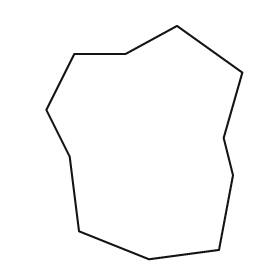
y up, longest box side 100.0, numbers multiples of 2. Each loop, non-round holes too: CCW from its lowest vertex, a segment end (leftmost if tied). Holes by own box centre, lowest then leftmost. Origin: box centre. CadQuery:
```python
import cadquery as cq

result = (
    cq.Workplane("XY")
    .moveTo(2.0, -50.0)
    .lineTo(32.0, -46.0)
    .lineTo(38.0, -14.0)
    .lineTo(34.0, 2.0)
    .lineTo(42.0, 30.0)
    .lineTo(14.0, 50.0)
    .lineTo(-8.0, 38.0)
    .lineTo(-30.0, 38.0)
    .lineTo(-42.0, 14.0)
    .lineTo(-32.0, -6.0)
    .lineTo(-28.0, -38.0)
    .close()
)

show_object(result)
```